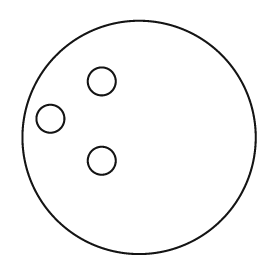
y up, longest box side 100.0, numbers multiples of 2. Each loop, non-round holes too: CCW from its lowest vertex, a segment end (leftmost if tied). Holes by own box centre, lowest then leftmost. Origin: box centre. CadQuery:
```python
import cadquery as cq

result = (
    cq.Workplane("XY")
    .moveTo(0.0, 0.0)
    .circle(50.0)
    .moveTo(-16.0, -10.0)
    .circle(6.0)
    .moveTo(-38.0, 8.0)
    .circle(6.0)
    .moveTo(-16.0, 24.0)
    .circle(6.0)
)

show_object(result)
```